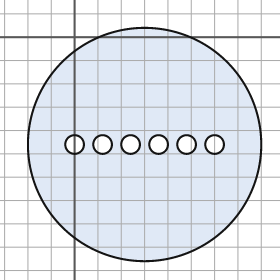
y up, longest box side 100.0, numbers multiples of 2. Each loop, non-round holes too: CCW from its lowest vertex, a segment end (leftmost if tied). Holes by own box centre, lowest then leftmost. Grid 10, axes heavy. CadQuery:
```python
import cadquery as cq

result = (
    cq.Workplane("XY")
    .moveTo(30.0, -46.0)
    .circle(50.0)
    .moveTo(0.0, -46.0)
    .circle(4.0)
    .moveTo(12.0, -46.0)
    .circle(4.0)
    .moveTo(24.0, -46.0)
    .circle(4.0)
    .moveTo(36.0, -46.0)
    .circle(4.0)
    .moveTo(48.0, -46.0)
    .circle(4.0)
    .moveTo(60.0, -46.0)
    .circle(4.0)
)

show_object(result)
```